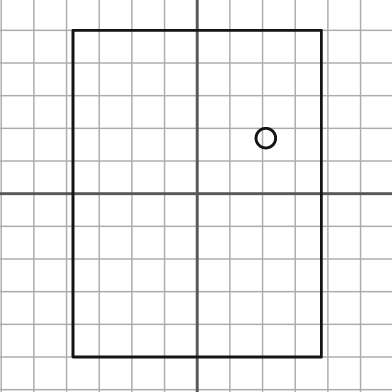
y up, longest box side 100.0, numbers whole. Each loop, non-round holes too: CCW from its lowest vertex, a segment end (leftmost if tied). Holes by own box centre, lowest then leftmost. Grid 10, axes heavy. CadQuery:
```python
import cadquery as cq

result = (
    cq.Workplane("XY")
    .moveTo(-38.0, -50.0)
    .lineTo(38.0, -50.0)
    .lineTo(38.0, 50.0)
    .lineTo(-38.0, 50.0)
    .close()
    .moveTo(21.0, 17.0)
    .circle(3.0)
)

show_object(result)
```